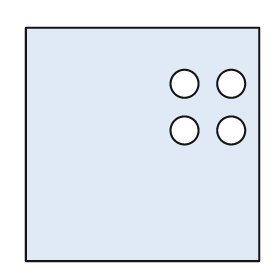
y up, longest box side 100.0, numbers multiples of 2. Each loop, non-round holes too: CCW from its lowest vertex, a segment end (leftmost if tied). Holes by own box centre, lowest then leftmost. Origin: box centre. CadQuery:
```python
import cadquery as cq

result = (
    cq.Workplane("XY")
    .moveTo(-50.0, -50.0)
    .lineTo(50.0, -50.0)
    .lineTo(50.0, 50.0)
    .lineTo(-50.0, 50.0)
    .close()
    .moveTo(18.0, 6.0)
    .circle(6.0)
    .moveTo(38.0, 6.0)
    .circle(6.0)
    .moveTo(18.0, 26.0)
    .circle(6.0)
    .moveTo(38.0, 26.0)
    .circle(6.0)
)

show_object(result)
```